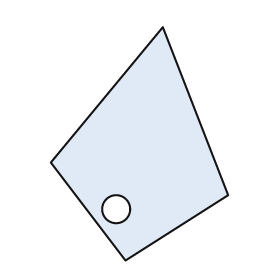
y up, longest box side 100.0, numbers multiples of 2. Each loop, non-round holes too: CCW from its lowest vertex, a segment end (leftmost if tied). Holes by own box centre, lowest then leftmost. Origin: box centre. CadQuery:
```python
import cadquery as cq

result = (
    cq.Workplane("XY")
    .moveTo(-6.0, -50.0)
    .lineTo(38.0, -22.0)
    .lineTo(10.0, 50.0)
    .lineTo(-38.0, -8.0)
    .close()
    .moveTo(-10.0, -28.0)
    .circle(6.0)
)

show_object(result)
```